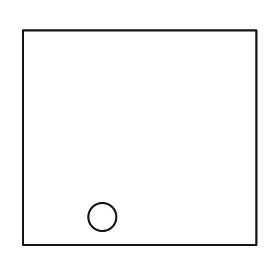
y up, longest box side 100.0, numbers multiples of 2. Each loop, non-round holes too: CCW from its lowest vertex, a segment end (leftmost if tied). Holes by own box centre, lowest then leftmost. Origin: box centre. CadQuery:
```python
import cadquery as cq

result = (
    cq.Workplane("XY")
    .moveTo(-50.0, -46.0)
    .lineTo(50.0, -46.0)
    .lineTo(50.0, 46.0)
    .lineTo(-50.0, 46.0)
    .close()
    .moveTo(-16.0, -34.0)
    .circle(6.0)
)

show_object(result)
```